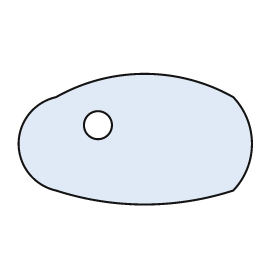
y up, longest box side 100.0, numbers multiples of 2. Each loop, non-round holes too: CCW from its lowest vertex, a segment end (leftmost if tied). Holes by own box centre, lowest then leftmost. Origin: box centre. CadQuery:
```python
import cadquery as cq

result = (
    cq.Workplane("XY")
    .moveTo(-34.0, -22.0)
    .threePointArc((4.0, -28.0), (42.0, -22.0))
    .threePointArc((50.0, -2.0), (42.0, 18.0))
    .threePointArc((4.0, 28.0), (-34.0, 18.0))
    .threePointArc((-50.0, -2.0), (-34.0, -22.0))
    .close()
    .moveTo(-16.0, 6.0)
    .circle(6.0)
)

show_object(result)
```